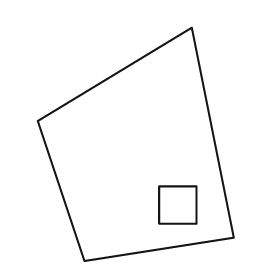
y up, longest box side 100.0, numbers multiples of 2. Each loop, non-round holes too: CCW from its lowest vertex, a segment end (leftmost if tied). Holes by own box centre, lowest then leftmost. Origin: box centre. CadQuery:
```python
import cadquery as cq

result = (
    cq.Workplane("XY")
    .moveTo(-22.0, -50.0)
    .lineTo(42.0, -40.0)
    .lineTo(24.0, 50.0)
    .lineTo(-42.0, 10.0)
    .close()
    .moveTo(10.0, -34.0)
    .lineTo(26.0, -34.0)
    .lineTo(26.0, -18.0)
    .lineTo(10.0, -18.0)
    .close()
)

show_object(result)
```